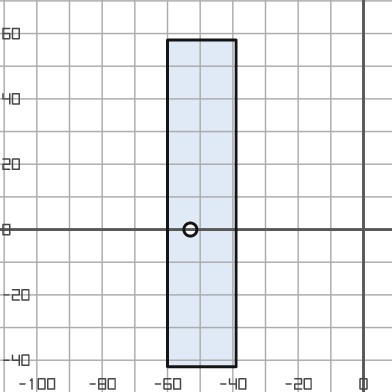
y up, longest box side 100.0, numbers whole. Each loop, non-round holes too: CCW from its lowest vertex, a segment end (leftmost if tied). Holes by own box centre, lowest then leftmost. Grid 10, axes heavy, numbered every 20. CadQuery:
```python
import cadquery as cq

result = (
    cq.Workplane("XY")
    .moveTo(-60.0, -42.0)
    .lineTo(-39.0, -42.0)
    .lineTo(-39.0, 58.0)
    .lineTo(-60.0, 58.0)
    .close()
    .moveTo(-53.0, 0.0)
    .circle(2.0)
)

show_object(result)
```